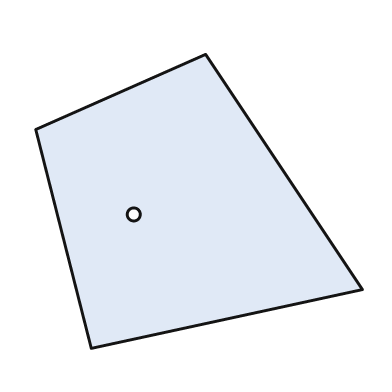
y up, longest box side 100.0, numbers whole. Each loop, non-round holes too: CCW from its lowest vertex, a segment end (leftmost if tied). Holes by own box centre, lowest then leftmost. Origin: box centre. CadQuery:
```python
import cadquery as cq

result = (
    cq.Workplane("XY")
    .moveTo(-33.0, -45.0)
    .lineTo(50.0, -27.0)
    .lineTo(2.0, 45.0)
    .lineTo(-50.0, 22.0)
    .close()
    .moveTo(-20.0, -4.0)
    .circle(2.0)
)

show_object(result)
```